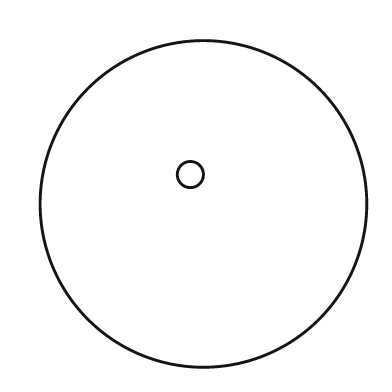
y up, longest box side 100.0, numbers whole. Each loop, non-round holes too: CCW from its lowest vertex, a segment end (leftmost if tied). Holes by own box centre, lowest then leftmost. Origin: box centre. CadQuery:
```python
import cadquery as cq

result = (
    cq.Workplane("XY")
    .moveTo(0.0, 0.0)
    .circle(50.0)
    .moveTo(-4.0, 9.0)
    .circle(4.0)
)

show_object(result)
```